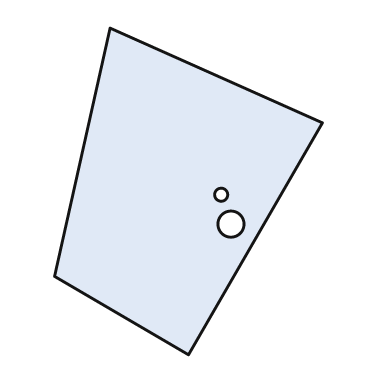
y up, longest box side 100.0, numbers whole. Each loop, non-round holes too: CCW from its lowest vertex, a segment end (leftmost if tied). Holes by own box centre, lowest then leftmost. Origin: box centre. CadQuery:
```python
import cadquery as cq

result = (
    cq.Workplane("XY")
    .moveTo(0.0, -50.0)
    .lineTo(41.0, 21.0)
    .lineTo(-24.0, 50.0)
    .lineTo(-41.0, -26.0)
    .close()
    .moveTo(13.0, -10.0)
    .circle(4.0)
    .moveTo(10.0, -1.0)
    .circle(2.0)
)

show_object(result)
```